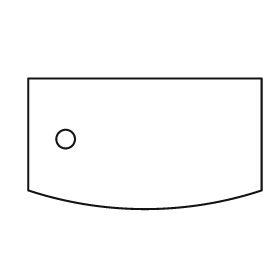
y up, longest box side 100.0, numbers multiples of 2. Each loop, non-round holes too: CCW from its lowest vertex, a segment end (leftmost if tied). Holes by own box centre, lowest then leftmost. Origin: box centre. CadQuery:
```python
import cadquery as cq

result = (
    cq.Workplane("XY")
    .moveTo(-50.0, -20.0)
    .threePointArc((0.0, -28.0), (50.0, -20.0))
    .lineTo(50.0, 28.0)
    .lineTo(-50.0, 28.0)
    .close()
    .moveTo(-34.0, 2.0)
    .circle(4.0)
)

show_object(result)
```